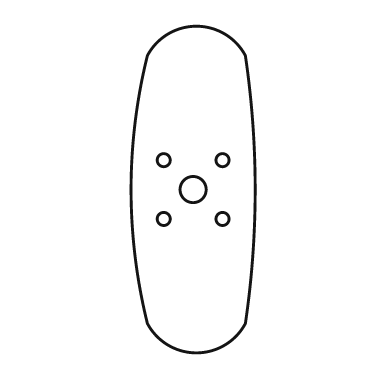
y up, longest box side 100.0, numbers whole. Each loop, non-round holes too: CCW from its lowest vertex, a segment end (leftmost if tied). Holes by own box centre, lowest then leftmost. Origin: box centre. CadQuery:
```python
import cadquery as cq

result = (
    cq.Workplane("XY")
    .moveTo(-14.0, -41.0)
    .threePointArc((1.0, -50.0), (16.0, -41.0))
    .threePointArc((19.0, 0.0), (16.0, 41.0))
    .threePointArc((1.0, 50.0), (-14.0, 41.0))
    .threePointArc((-19.0, 0.0), (-14.0, -41.0))
    .close()
    .moveTo(-9.0, -9.0)
    .circle(2.0)
    .moveTo(9.0, -9.0)
    .circle(2.0)
    .moveTo(0.0, 0.0)
    .circle(4.0)
    .moveTo(-9.0, 9.0)
    .circle(2.0)
    .moveTo(9.0, 9.0)
    .circle(2.0)
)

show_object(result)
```